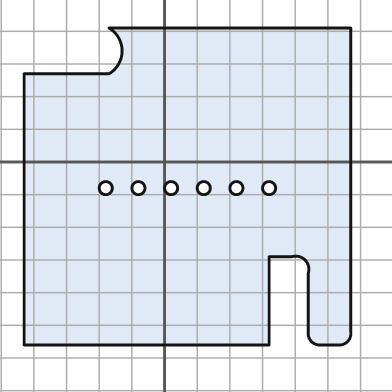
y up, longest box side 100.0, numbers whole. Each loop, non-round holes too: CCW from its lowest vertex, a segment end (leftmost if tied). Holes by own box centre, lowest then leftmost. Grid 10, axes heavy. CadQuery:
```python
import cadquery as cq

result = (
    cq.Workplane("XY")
    .moveTo(-43.0, -56.0)
    .lineTo(32.0, -56.0)
    .lineTo(32.0, -29.0)
    .lineTo(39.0, -29.0)
    .threePointArc((43.0, -30.0), (44.0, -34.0))
    .lineTo(44.0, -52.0)
    .threePointArc((45.0, -55.0), (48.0, -56.0))
    .lineTo(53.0, -56.0)
    .threePointArc((56.0, -55.0), (57.0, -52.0))
    .lineTo(57.0, 41.0)
    .lineTo(-17.0, 41.0)
    .threePointArc((-13.0, 34.0), (-17.0, 27.0))
    .lineTo(-43.0, 27.0)
    .close()
    .moveTo(-18.0, -8.0)
    .circle(2.0)
    .moveTo(-8.0, -8.0)
    .circle(2.0)
    .moveTo(2.0, -8.0)
    .circle(2.0)
    .moveTo(12.0, -8.0)
    .circle(2.0)
    .moveTo(22.0, -8.0)
    .circle(2.0)
    .moveTo(32.0, -8.0)
    .circle(2.0)
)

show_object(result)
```